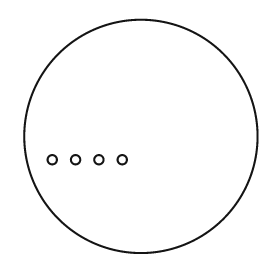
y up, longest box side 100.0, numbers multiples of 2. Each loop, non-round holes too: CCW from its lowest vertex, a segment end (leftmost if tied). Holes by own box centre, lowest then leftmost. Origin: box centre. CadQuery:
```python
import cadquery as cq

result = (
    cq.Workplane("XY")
    .moveTo(0.0, 0.0)
    .circle(50.0)
    .moveTo(-38.0, -10.0)
    .circle(2.0)
    .moveTo(-28.0, -10.0)
    .circle(2.0)
    .moveTo(-18.0, -10.0)
    .circle(2.0)
    .moveTo(-8.0, -10.0)
    .circle(2.0)
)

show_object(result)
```